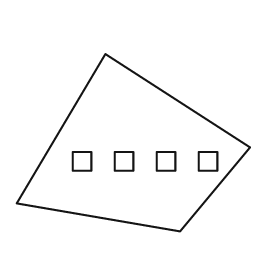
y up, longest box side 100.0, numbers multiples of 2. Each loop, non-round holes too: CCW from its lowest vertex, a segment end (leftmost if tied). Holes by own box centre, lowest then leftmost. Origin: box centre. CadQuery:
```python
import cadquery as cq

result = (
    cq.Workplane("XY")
    .moveTo(20.0, -38.0)
    .lineTo(50.0, -2.0)
    .lineTo(-12.0, 38.0)
    .lineTo(-50.0, -26.0)
    .close()
    .moveTo(-26.0, -12.0)
    .lineTo(-18.0, -12.0)
    .lineTo(-18.0, -4.0)
    .lineTo(-26.0, -4.0)
    .close()
    .moveTo(-8.0, -12.0)
    .lineTo(0.0, -12.0)
    .lineTo(0.0, -4.0)
    .lineTo(-8.0, -4.0)
    .close()
    .moveTo(10.0, -12.0)
    .lineTo(18.0, -12.0)
    .lineTo(18.0, -4.0)
    .lineTo(10.0, -4.0)
    .close()
    .moveTo(28.0, -12.0)
    .lineTo(36.0, -12.0)
    .lineTo(36.0, -4.0)
    .lineTo(28.0, -4.0)
    .close()
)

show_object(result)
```